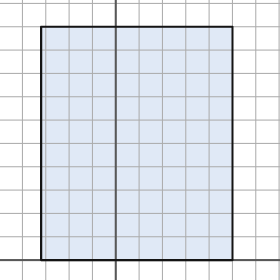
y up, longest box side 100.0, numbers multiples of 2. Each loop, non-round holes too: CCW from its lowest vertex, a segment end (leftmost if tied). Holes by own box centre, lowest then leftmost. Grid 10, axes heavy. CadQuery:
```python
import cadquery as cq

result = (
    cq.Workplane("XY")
    .moveTo(-32.0, 0.0)
    .lineTo(50.0, 0.0)
    .lineTo(50.0, 100.0)
    .lineTo(-32.0, 100.0)
    .close()
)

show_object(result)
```